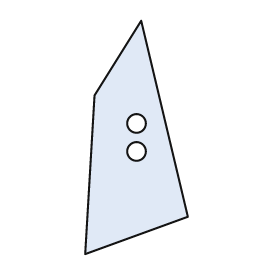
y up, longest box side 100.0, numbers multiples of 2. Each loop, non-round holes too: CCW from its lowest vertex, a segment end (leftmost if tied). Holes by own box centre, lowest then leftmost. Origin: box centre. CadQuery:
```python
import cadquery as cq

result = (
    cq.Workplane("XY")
    .moveTo(-22.0, -50.0)
    .lineTo(22.0, -34.0)
    .lineTo(2.0, 50.0)
    .lineTo(-18.0, 18.0)
    .close()
    .moveTo(0.0, -6.0)
    .circle(4.0)
    .moveTo(0.0, 6.0)
    .circle(4.0)
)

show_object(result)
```